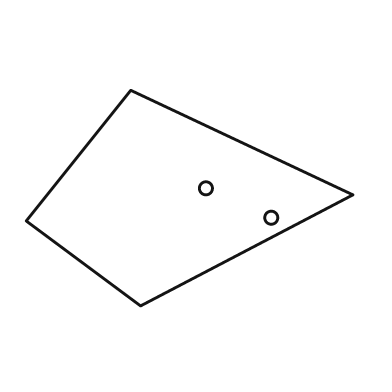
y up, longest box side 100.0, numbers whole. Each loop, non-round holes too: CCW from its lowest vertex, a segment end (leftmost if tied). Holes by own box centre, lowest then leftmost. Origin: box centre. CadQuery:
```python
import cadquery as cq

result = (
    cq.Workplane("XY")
    .moveTo(-15.0, -33.0)
    .lineTo(50.0, 1.0)
    .lineTo(-18.0, 33.0)
    .lineTo(-50.0, -7.0)
    .close()
    .moveTo(25.0, -6.0)
    .circle(2.0)
    .moveTo(5.0, 3.0)
    .circle(2.0)
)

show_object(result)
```